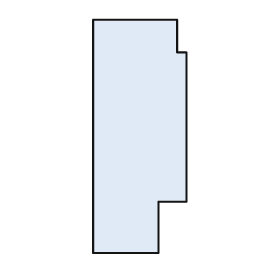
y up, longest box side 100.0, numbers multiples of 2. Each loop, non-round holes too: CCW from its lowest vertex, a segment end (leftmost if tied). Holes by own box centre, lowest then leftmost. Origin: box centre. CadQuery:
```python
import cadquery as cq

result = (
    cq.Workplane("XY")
    .moveTo(-20.0, -50.0)
    .lineTo(8.0, -50.0)
    .lineTo(8.0, -28.0)
    .lineTo(20.0, -28.0)
    .lineTo(20.0, 36.0)
    .lineTo(16.0, 36.0)
    .lineTo(16.0, 50.0)
    .lineTo(-20.0, 50.0)
    .close()
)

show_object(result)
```